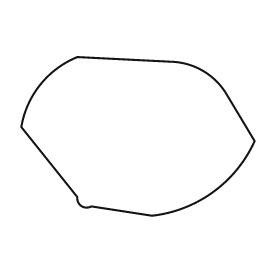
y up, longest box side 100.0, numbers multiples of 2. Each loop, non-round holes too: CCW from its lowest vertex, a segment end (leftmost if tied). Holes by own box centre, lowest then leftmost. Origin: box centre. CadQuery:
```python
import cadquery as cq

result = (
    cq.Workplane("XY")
    .moveTo(6.0, -34.0)
    .threePointArc((32.0, -24.0), (50.0, -2.0))
    .lineTo(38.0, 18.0)
    .threePointArc((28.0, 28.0), (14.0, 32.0))
    .lineTo(-26.0, 34.0)
    .threePointArc((-42.0, 22.0), (-50.0, 4.0))
    .lineTo(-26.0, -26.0)
    .threePointArc((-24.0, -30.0), (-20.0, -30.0))
    .close()
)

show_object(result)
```